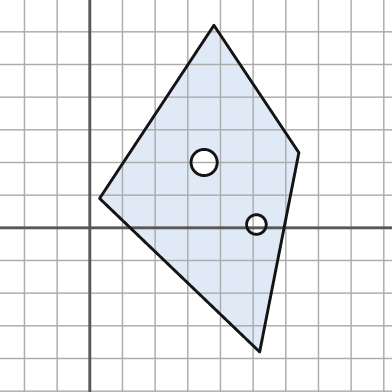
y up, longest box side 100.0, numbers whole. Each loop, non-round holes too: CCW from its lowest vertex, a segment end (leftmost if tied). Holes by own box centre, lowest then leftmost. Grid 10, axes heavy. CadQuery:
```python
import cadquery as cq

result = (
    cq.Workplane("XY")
    .moveTo(52.0, -38.0)
    .lineTo(64.0, 23.0)
    .lineTo(38.0, 62.0)
    .lineTo(3.0, 9.0)
    .close()
    .moveTo(51.0, 1.0)
    .circle(3.0)
    .moveTo(35.0, 20.0)
    .circle(4.0)
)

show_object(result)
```